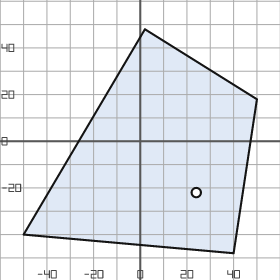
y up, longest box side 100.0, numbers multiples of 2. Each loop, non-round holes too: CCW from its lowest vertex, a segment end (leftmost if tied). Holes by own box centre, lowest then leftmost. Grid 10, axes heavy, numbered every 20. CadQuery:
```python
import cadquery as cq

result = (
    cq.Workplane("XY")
    .moveTo(40.0, -48.0)
    .lineTo(50.0, 18.0)
    .lineTo(2.0, 48.0)
    .lineTo(-50.0, -40.0)
    .close()
    .moveTo(24.0, -22.0)
    .circle(2.0)
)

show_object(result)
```